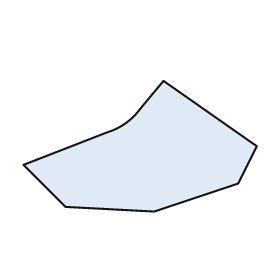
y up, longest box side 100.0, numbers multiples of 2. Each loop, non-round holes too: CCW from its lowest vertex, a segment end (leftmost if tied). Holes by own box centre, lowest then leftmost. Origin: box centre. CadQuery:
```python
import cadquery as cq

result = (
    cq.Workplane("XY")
    .moveTo(6.0, -28.0)
    .lineTo(42.0, -16.0)
    .lineTo(50.0, 0.0)
    .lineTo(10.0, 28.0)
    .lineTo(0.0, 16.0)
    .threePointArc((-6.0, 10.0), (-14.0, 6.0))
    .lineTo(-50.0, -8.0)
    .lineTo(-32.0, -26.0)
    .close()
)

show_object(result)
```